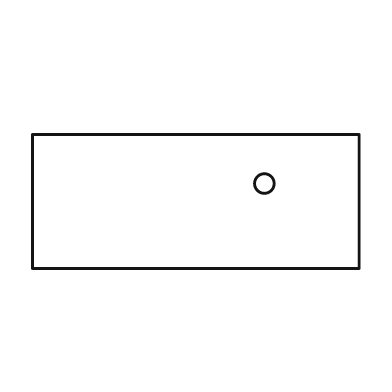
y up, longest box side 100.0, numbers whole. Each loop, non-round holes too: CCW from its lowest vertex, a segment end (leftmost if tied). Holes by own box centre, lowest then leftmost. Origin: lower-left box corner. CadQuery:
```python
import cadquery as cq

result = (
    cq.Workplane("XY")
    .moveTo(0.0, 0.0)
    .lineTo(100.0, 0.0)
    .lineTo(100.0, 41.0)
    .lineTo(0.0, 41.0)
    .close()
    .moveTo(71.0, 26.0)
    .circle(3.0)
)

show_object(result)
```